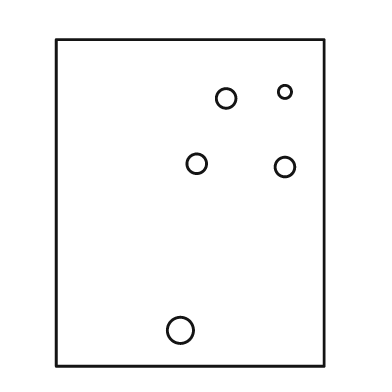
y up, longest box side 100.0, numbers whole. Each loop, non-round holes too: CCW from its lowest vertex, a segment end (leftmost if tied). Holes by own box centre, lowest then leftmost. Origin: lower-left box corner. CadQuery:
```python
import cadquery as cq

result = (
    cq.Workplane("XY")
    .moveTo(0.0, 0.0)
    .lineTo(82.0, 0.0)
    .lineTo(82.0, 100.0)
    .lineTo(0.0, 100.0)
    .close()
    .moveTo(38.0, 11.0)
    .circle(4.0)
    .moveTo(70.0, 61.0)
    .circle(3.0)
    .moveTo(43.0, 62.0)
    .circle(3.0)
    .moveTo(52.0, 82.0)
    .circle(3.0)
    .moveTo(70.0, 84.0)
    .circle(2.0)
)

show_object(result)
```